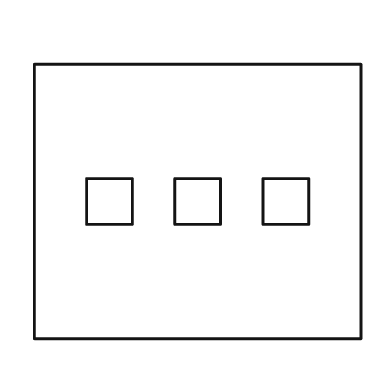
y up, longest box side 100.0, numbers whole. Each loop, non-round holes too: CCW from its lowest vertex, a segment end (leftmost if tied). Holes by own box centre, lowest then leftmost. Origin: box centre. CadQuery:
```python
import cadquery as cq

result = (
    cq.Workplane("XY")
    .moveTo(-50.0, -42.0)
    .lineTo(50.0, -42.0)
    .lineTo(50.0, 42.0)
    .lineTo(-50.0, 42.0)
    .close()
    .moveTo(-34.0, -7.0)
    .lineTo(-20.0, -7.0)
    .lineTo(-20.0, 7.0)
    .lineTo(-34.0, 7.0)
    .close()
    .moveTo(-7.0, -7.0)
    .lineTo(7.0, -7.0)
    .lineTo(7.0, 7.0)
    .lineTo(-7.0, 7.0)
    .close()
    .moveTo(20.0, -7.0)
    .lineTo(34.0, -7.0)
    .lineTo(34.0, 7.0)
    .lineTo(20.0, 7.0)
    .close()
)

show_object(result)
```